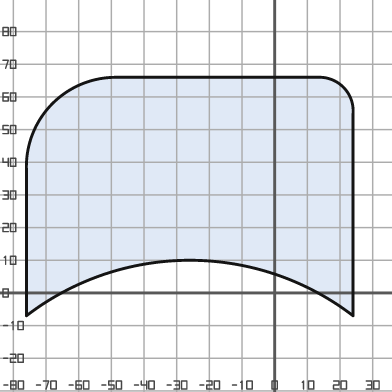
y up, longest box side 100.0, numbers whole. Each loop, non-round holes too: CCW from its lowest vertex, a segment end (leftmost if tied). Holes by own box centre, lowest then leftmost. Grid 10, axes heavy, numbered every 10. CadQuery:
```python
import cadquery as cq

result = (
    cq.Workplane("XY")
    .moveTo(-76.0, -7.0)
    .threePointArc((-26.0, 10.0), (24.0, -7.0))
    .lineTo(24.0, 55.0)
    .threePointArc((21.0, 63.0), (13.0, 66.0))
    .lineTo(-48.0, 66.0)
    .threePointArc((-68.0, 58.0), (-76.0, 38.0))
    .close()
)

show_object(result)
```